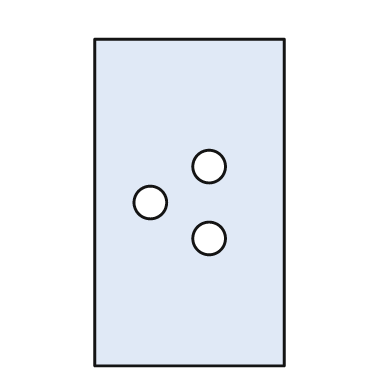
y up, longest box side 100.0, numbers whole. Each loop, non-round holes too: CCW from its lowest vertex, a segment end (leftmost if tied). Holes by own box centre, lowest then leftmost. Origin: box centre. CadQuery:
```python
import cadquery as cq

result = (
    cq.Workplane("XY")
    .moveTo(-29.0, -50.0)
    .lineTo(29.0, -50.0)
    .lineTo(29.0, 50.0)
    .lineTo(-29.0, 50.0)
    .close()
    .moveTo(6.0, -11.0)
    .circle(5.0)
    .moveTo(-12.0, 0.0)
    .circle(5.0)
    .moveTo(6.0, 11.0)
    .circle(5.0)
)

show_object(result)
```